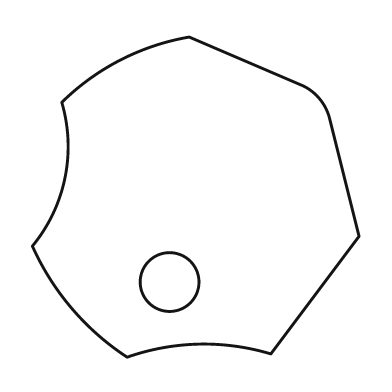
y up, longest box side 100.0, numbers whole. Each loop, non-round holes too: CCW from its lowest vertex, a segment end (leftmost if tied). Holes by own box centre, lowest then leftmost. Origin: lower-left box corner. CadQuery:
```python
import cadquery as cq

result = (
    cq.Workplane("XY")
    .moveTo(29.0, 0.0)
    .threePointArc((51.0, 4.0), (73.0, 1.0))
    .lineTo(100.0, 37.0)
    .lineTo(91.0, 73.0)
    .threePointArc((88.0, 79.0), (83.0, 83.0))
    .lineTo(48.0, 98.0)
    .threePointArc((27.0, 91.0), (9.0, 78.0))
    .threePointArc((10.0, 55.0), (0.0, 34.0))
    .threePointArc((12.0, 15.0), (29.0, 0.0))
    .close()
    .moveTo(42.0, 23.0)
    .circle(9.0)
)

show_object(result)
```